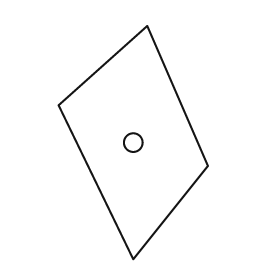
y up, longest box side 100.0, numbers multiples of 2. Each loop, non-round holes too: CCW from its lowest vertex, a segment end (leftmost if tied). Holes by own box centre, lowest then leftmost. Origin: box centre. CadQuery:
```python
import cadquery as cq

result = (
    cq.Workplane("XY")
    .moveTo(0.0, -50.0)
    .lineTo(32.0, -10.0)
    .lineTo(6.0, 50.0)
    .lineTo(-32.0, 16.0)
    .close()
    .moveTo(0.0, 0.0)
    .circle(4.0)
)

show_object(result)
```